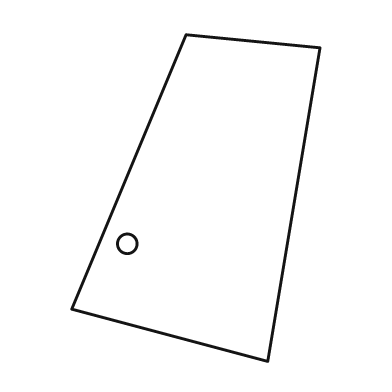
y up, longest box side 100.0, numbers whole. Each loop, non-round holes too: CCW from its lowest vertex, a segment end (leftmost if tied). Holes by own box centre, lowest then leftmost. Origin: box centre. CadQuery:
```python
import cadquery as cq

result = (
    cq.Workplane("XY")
    .moveTo(22.0, -50.0)
    .lineTo(38.0, 46.0)
    .lineTo(-3.0, 50.0)
    .lineTo(-38.0, -34.0)
    .close()
    .moveTo(-21.0, -14.0)
    .circle(3.0)
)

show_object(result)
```